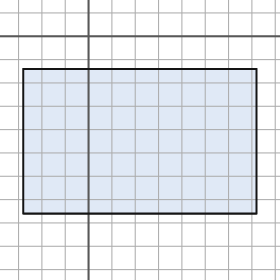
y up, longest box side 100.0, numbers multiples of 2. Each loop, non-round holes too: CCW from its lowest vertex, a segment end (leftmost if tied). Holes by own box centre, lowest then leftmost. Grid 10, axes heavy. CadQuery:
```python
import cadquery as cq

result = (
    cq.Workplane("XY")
    .moveTo(-28.0, -76.0)
    .lineTo(72.0, -76.0)
    .lineTo(72.0, -14.0)
    .lineTo(-28.0, -14.0)
    .close()
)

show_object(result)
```